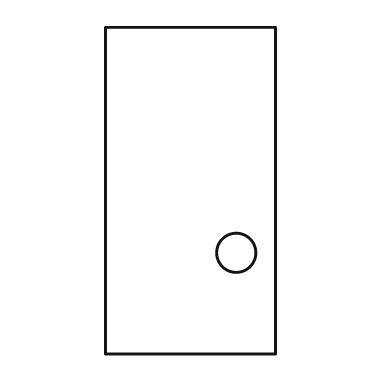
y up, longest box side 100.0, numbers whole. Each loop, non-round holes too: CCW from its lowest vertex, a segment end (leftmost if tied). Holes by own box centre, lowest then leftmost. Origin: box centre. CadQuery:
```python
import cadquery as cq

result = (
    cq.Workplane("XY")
    .moveTo(-26.0, -50.0)
    .lineTo(26.0, -50.0)
    .lineTo(26.0, 50.0)
    .lineTo(-26.0, 50.0)
    .close()
    .moveTo(14.0, -19.0)
    .circle(6.0)
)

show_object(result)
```